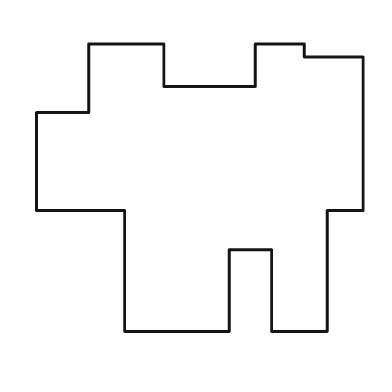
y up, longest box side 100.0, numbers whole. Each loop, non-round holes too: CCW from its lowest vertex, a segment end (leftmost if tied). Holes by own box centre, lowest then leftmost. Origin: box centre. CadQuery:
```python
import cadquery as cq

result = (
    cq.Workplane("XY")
    .moveTo(-23.0, -44.0)
    .lineTo(9.0, -44.0)
    .lineTo(9.0, -19.0)
    .lineTo(22.0, -19.0)
    .lineTo(22.0, -44.0)
    .lineTo(39.0, -44.0)
    .lineTo(39.0, -7.0)
    .lineTo(50.0, -7.0)
    .lineTo(50.0, 40.0)
    .lineTo(32.0, 40.0)
    .lineTo(32.0, 44.0)
    .lineTo(17.0, 44.0)
    .lineTo(17.0, 31.0)
    .lineTo(-11.0, 31.0)
    .lineTo(-11.0, 44.0)
    .lineTo(-34.0, 44.0)
    .lineTo(-34.0, 23.0)
    .lineTo(-50.0, 23.0)
    .lineTo(-50.0, -7.0)
    .lineTo(-23.0, -7.0)
    .close()
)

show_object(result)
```